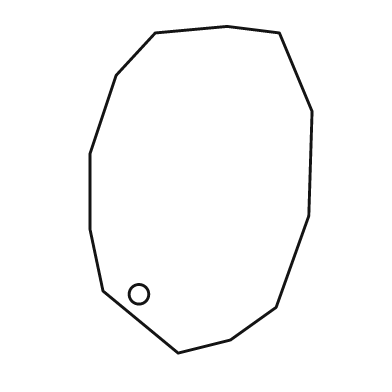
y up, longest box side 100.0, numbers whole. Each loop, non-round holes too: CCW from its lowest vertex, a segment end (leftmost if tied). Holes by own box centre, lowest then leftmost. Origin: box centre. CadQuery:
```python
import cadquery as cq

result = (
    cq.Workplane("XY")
    .moveTo(-7.0, -50.0)
    .lineTo(9.0, -46.0)
    .lineTo(23.0, -36.0)
    .lineTo(33.0, -8.0)
    .lineTo(34.0, 24.0)
    .lineTo(24.0, 48.0)
    .lineTo(8.0, 50.0)
    .lineTo(-14.0, 48.0)
    .lineTo(-26.0, 35.0)
    .lineTo(-34.0, 11.0)
    .lineTo(-34.0, -12.0)
    .lineTo(-30.0, -31.0)
    .close()
    .moveTo(-19.0, -32.0)
    .circle(3.0)
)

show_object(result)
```